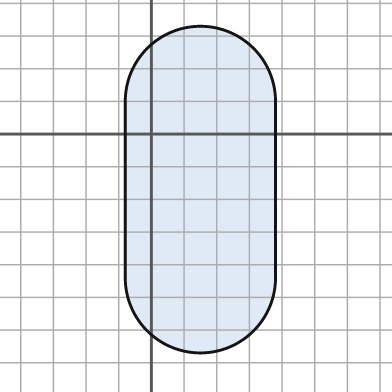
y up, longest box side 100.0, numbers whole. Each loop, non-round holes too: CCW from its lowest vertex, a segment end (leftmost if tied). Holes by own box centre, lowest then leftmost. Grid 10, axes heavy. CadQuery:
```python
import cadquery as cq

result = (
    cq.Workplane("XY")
    .moveTo(-8.0, -44.0)
    .threePointArc((15.0, -67.0), (38.0, -44.0))
    .lineTo(38.0, 10.0)
    .threePointArc((15.0, 33.0), (-8.0, 10.0))
    .close()
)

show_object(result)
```